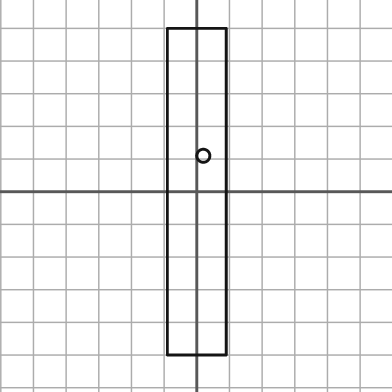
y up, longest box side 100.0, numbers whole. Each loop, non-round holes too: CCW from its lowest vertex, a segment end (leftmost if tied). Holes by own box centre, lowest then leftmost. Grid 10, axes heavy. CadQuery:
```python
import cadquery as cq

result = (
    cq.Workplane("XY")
    .moveTo(-9.0, -50.0)
    .lineTo(9.0, -50.0)
    .lineTo(9.0, 50.0)
    .lineTo(-9.0, 50.0)
    .close()
    .moveTo(2.0, 11.0)
    .circle(2.0)
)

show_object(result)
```